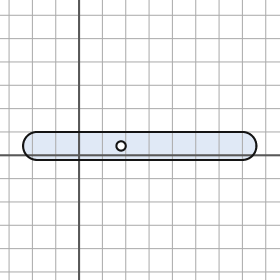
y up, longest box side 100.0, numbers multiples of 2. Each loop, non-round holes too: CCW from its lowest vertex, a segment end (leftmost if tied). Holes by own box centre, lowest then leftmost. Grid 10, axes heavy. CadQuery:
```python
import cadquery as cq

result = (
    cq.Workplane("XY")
    .moveTo(-18.0, -2.0)
    .lineTo(70.0, -2.0)
    .threePointArc((76.0, 4.0), (70.0, 10.0))
    .lineTo(-18.0, 10.0)
    .threePointArc((-24.0, 4.0), (-18.0, -2.0))
    .close()
    .moveTo(18.0, 4.0)
    .circle(2.0)
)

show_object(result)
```